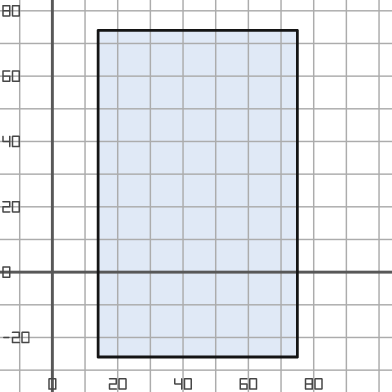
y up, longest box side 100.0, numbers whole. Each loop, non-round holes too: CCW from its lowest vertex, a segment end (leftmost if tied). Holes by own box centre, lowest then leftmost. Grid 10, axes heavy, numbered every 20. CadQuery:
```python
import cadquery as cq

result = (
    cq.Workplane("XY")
    .moveTo(14.0, -26.0)
    .lineTo(75.0, -26.0)
    .lineTo(75.0, 74.0)
    .lineTo(14.0, 74.0)
    .close()
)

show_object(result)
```